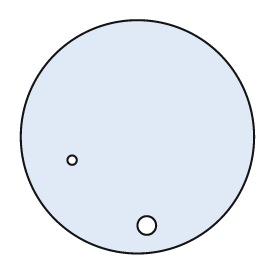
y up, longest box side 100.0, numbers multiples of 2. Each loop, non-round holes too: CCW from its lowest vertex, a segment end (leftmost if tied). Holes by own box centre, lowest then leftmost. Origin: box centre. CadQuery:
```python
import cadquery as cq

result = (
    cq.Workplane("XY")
    .moveTo(0.0, 0.0)
    .circle(50.0)
    .moveTo(4.0, -38.0)
    .circle(4.0)
    .moveTo(-28.0, -10.0)
    .circle(2.0)
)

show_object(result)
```